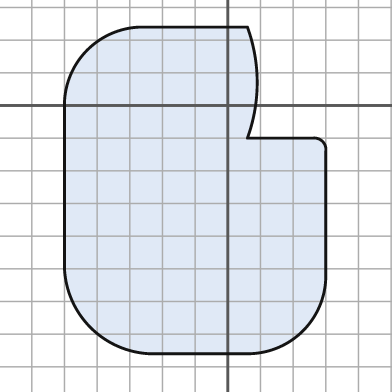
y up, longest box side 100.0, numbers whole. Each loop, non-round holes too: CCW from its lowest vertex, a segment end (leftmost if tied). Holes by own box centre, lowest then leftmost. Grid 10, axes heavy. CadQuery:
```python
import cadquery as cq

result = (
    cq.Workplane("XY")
    .moveTo(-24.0, -76.0)
    .lineTo(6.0, -76.0)
    .threePointArc((23.0, -69.0), (30.0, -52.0))
    .lineTo(30.0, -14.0)
    .threePointArc((29.0, -11.0), (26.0, -10.0))
    .lineTo(6.0, -10.0)
    .threePointArc((9.0, 7.0), (6.0, 24.0))
    .lineTo(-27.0, 24.0)
    .threePointArc((-43.0, 17.0), (-50.0, 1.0))
    .lineTo(-50.0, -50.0)
    .threePointArc((-42.0, -68.0), (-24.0, -76.0))
    .close()
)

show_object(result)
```